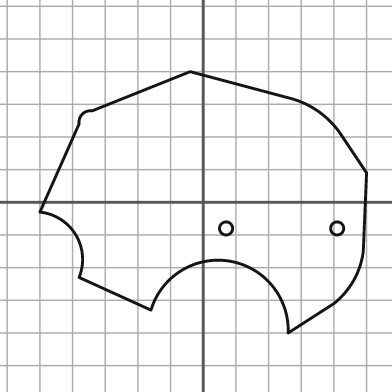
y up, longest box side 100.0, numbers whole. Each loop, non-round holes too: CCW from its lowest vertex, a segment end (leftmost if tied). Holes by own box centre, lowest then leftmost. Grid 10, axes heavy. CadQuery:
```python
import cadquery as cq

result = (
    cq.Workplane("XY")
    .moveTo(26.0, -40.0)
    .lineTo(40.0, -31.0)
    .threePointArc((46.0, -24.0), (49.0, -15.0))
    .lineTo(50.0, 9.0)
    .lineTo(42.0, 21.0)
    .threePointArc((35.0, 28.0), (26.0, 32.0))
    .lineTo(-4.0, 40.0)
    .lineTo(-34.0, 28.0)
    .threePointArc((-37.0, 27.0), (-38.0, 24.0))
    .lineTo(-50.0, -3.0)
    .threePointArc((-39.0, -10.0), (-38.0, -23.0))
    .lineTo(-16.0, -33.0)
    .threePointArc((8.0, -18.0), (26.0, -40.0))
    .close()
    .moveTo(7.0, -8.0)
    .circle(2.0)
    .moveTo(41.0, -8.0)
    .circle(2.0)
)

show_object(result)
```